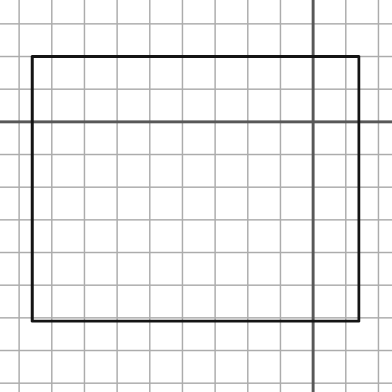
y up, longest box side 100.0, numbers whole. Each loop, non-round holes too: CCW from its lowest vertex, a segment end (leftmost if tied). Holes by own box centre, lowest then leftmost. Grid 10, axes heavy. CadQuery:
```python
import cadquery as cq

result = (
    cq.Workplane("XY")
    .moveTo(-86.0, -61.0)
    .lineTo(14.0, -61.0)
    .lineTo(14.0, 20.0)
    .lineTo(-86.0, 20.0)
    .close()
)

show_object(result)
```